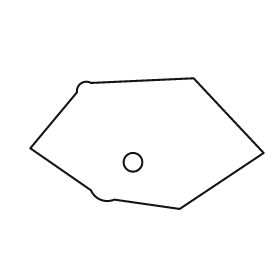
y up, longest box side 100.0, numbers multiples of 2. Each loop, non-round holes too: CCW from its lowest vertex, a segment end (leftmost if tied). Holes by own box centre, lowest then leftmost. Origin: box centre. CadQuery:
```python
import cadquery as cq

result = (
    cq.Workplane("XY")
    .moveTo(14.0, -28.0)
    .lineTo(50.0, -4.0)
    .lineTo(20.0, 28.0)
    .lineTo(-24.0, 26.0)
    .threePointArc((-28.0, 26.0), (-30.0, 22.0))
    .lineTo(-50.0, -2.0)
    .lineTo(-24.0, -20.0)
    .threePointArc((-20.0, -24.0), (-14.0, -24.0))
    .close()
    .moveTo(-6.0, -8.0)
    .circle(4.0)
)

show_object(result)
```